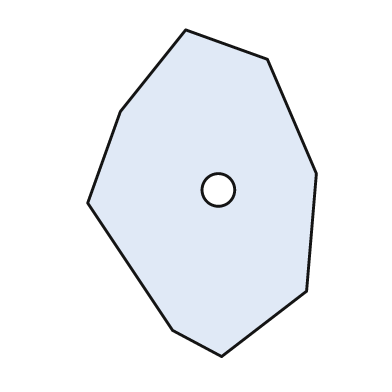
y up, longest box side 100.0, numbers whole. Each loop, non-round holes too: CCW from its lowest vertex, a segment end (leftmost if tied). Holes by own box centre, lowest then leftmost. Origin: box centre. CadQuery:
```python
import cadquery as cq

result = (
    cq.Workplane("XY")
    .moveTo(6.0, -50.0)
    .lineTo(32.0, -30.0)
    .lineTo(35.0, 6.0)
    .lineTo(20.0, 41.0)
    .lineTo(-5.0, 50.0)
    .lineTo(-25.0, 25.0)
    .lineTo(-35.0, -3.0)
    .lineTo(-9.0, -42.0)
    .close()
    .moveTo(5.0, 1.0)
    .circle(5.0)
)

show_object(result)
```